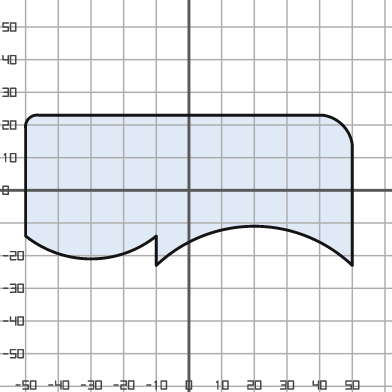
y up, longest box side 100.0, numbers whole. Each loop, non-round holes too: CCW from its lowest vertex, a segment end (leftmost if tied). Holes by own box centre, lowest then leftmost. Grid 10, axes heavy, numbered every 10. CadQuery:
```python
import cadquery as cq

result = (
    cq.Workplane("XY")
    .moveTo(-10.0, -23.0)
    .threePointArc((20.0, -11.0), (50.0, -23.0))
    .lineTo(50.0, 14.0)
    .threePointArc((47.0, 20.0), (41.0, 23.0))
    .lineTo(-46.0, 23.0)
    .threePointArc((-49.0, 22.0), (-50.0, 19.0))
    .lineTo(-50.0, -14.0)
    .threePointArc((-30.0, -21.0), (-10.0, -14.0))
    .close()
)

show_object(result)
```